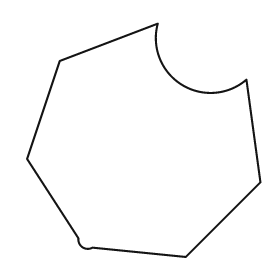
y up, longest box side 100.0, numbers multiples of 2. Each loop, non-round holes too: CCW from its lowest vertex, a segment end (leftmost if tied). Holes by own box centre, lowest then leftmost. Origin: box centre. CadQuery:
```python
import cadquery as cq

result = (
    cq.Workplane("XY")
    .moveTo(18.0, -50.0)
    .lineTo(50.0, -18.0)
    .lineTo(44.0, 26.0)
    .threePointArc((16.0, 24.0), (6.0, 50.0))
    .lineTo(-36.0, 34.0)
    .lineTo(-50.0, -8.0)
    .lineTo(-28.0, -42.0)
    .threePointArc((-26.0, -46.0), (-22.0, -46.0))
    .close()
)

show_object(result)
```